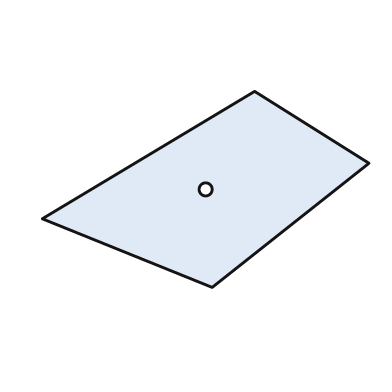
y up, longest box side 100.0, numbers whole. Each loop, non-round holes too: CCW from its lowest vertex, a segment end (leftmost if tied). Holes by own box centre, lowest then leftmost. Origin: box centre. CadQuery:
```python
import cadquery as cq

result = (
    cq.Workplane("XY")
    .moveTo(2.0, -30.0)
    .lineTo(50.0, 8.0)
    .lineTo(15.0, 30.0)
    .lineTo(-50.0, -9.0)
    .close()
    .moveTo(0.0, 0.0)
    .circle(2.0)
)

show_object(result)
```